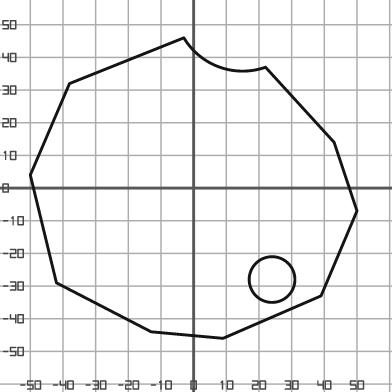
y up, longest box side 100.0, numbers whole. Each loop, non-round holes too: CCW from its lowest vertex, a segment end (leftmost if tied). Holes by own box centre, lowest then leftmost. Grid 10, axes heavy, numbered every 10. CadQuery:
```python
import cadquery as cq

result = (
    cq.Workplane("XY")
    .moveTo(9.0, -46.0)
    .lineTo(39.0, -33.0)
    .lineTo(50.0, -7.0)
    .lineTo(43.0, 14.0)
    .lineTo(22.0, 37.0)
    .threePointArc((8.0, 37.0), (-3.0, 46.0))
    .lineTo(-38.0, 32.0)
    .lineTo(-50.0, 4.0)
    .lineTo(-42.0, -29.0)
    .lineTo(-13.0, -44.0)
    .close()
    .moveTo(24.0, -28.0)
    .circle(7.0)
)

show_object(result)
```